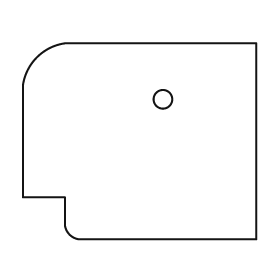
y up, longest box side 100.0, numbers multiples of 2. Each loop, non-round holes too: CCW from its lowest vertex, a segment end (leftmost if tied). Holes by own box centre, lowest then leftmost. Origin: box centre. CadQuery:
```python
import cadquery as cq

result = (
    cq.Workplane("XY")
    .moveTo(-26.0, -42.0)
    .lineTo(50.0, -42.0)
    .lineTo(50.0, 42.0)
    .lineTo(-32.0, 42.0)
    .threePointArc((-44.0, 36.0), (-50.0, 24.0))
    .lineTo(-50.0, -24.0)
    .lineTo(-32.0, -24.0)
    .lineTo(-32.0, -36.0)
    .threePointArc((-30.0, -40.0), (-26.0, -42.0))
    .close()
    .moveTo(10.0, 18.0)
    .circle(4.0)
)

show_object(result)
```